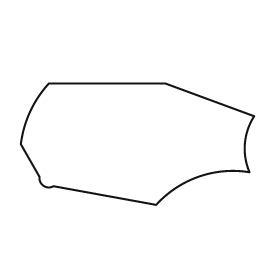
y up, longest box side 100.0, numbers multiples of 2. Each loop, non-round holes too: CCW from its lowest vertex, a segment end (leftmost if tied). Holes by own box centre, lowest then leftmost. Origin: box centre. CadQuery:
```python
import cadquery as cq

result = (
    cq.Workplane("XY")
    .moveTo(8.0, -26.0)
    .threePointArc((26.0, -14.0), (48.0, -12.0))
    .threePointArc((46.0, 0.0), (50.0, 12.0))
    .lineTo(12.0, 26.0)
    .lineTo(-38.0, 26.0)
    .threePointArc((-46.0, 14.0), (-50.0, 0.0))
    .lineTo(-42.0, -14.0)
    .threePointArc((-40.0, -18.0), (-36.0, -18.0))
    .close()
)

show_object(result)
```